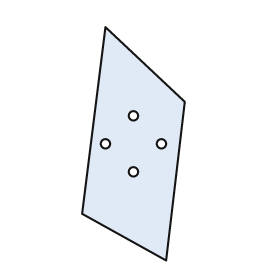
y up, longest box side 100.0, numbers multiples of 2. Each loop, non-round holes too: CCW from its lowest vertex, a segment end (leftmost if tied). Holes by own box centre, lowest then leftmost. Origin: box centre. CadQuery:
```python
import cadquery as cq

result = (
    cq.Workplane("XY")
    .moveTo(14.0, -50.0)
    .lineTo(22.0, 18.0)
    .lineTo(-12.0, 50.0)
    .lineTo(-22.0, -30.0)
    .close()
    .moveTo(0.0, -12.0)
    .circle(2.0)
    .moveTo(-12.0, 0.0)
    .circle(2.0)
    .moveTo(12.0, 0.0)
    .circle(2.0)
    .moveTo(0.0, 12.0)
    .circle(2.0)
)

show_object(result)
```